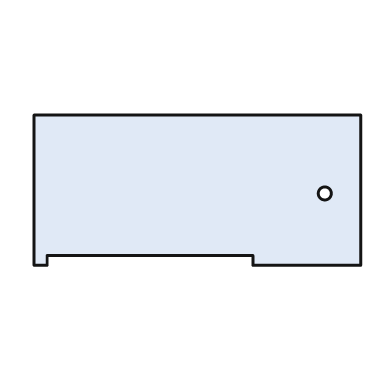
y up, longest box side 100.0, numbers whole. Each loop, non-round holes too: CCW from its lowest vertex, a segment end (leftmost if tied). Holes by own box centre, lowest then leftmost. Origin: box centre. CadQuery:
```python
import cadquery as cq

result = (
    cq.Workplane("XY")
    .moveTo(-50.0, -23.0)
    .lineTo(-46.0, -23.0)
    .lineTo(-46.0, -20.0)
    .lineTo(17.0, -20.0)
    .lineTo(17.0, -23.0)
    .lineTo(50.0, -23.0)
    .lineTo(50.0, 23.0)
    .lineTo(-50.0, 23.0)
    .close()
    .moveTo(39.0, -1.0)
    .circle(2.0)
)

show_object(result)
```